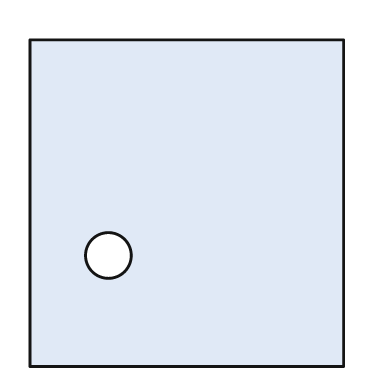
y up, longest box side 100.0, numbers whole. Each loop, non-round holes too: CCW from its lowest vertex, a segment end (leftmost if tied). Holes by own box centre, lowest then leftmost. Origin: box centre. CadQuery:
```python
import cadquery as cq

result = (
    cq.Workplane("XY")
    .moveTo(-48.0, -50.0)
    .lineTo(48.0, -50.0)
    .lineTo(48.0, 50.0)
    .lineTo(-48.0, 50.0)
    .close()
    .moveTo(-24.0, -16.0)
    .circle(7.0)
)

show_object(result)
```